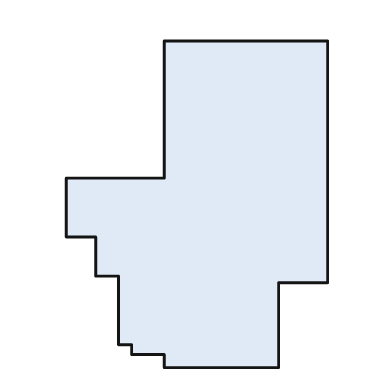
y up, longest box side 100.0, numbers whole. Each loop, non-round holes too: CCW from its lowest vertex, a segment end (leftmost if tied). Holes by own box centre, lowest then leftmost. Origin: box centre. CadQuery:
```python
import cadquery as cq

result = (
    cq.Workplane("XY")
    .moveTo(-10.0, -50.0)
    .lineTo(25.0, -50.0)
    .lineTo(25.0, -24.0)
    .lineTo(40.0, -24.0)
    .lineTo(40.0, 50.0)
    .lineTo(-10.0, 50.0)
    .lineTo(-10.0, 8.0)
    .lineTo(-40.0, 8.0)
    .lineTo(-40.0, -10.0)
    .lineTo(-31.0, -10.0)
    .lineTo(-31.0, -22.0)
    .lineTo(-24.0, -22.0)
    .lineTo(-24.0, -43.0)
    .lineTo(-20.0, -43.0)
    .lineTo(-20.0, -46.0)
    .lineTo(-10.0, -46.0)
    .close()
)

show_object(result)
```